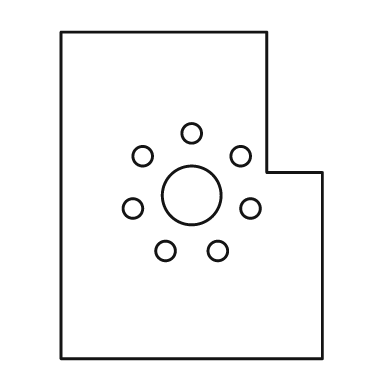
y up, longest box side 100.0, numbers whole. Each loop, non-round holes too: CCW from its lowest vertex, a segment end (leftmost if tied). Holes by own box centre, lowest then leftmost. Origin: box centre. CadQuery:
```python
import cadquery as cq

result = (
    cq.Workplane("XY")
    .moveTo(-40.0, -50.0)
    .lineTo(40.0, -50.0)
    .lineTo(40.0, 7.0)
    .lineTo(23.0, 7.0)
    .lineTo(23.0, 50.0)
    .lineTo(-40.0, 50.0)
    .close()
    .moveTo(-8.0, -17.0)
    .circle(3.0)
    .moveTo(8.0, -17.0)
    .circle(3.0)
    .moveTo(-18.0, -4.0)
    .circle(3.0)
    .moveTo(18.0, -4.0)
    .circle(3.0)
    .moveTo(0.0, 0.0)
    .circle(9.0)
    .moveTo(-15.0, 12.0)
    .circle(3.0)
    .moveTo(15.0, 12.0)
    .circle(3.0)
    .moveTo(0.0, 19.0)
    .circle(3.0)
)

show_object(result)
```